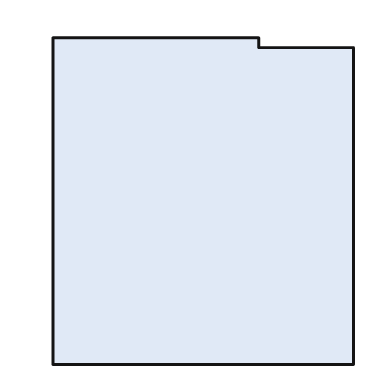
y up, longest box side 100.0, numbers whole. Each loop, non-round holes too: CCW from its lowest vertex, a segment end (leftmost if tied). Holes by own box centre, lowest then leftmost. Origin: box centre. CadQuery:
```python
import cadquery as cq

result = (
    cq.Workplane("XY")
    .moveTo(-46.0, -50.0)
    .lineTo(46.0, -50.0)
    .lineTo(46.0, 47.0)
    .lineTo(17.0, 47.0)
    .lineTo(17.0, 50.0)
    .lineTo(-46.0, 50.0)
    .close()
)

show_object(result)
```